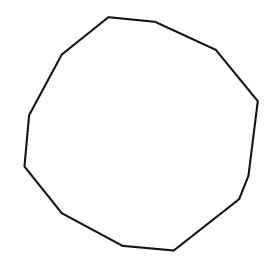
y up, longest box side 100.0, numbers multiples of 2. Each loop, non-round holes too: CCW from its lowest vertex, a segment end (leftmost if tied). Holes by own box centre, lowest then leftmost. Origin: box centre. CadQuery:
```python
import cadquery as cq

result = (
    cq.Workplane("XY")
    .moveTo(14.0, -50.0)
    .lineTo(42.0, -28.0)
    .lineTo(46.0, -18.0)
    .lineTo(50.0, 14.0)
    .lineTo(32.0, 36.0)
    .lineTo(6.0, 48.0)
    .lineTo(-14.0, 50.0)
    .lineTo(-34.0, 34.0)
    .lineTo(-48.0, 8.0)
    .lineTo(-50.0, -14.0)
    .lineTo(-34.0, -34.0)
    .lineTo(-8.0, -48.0)
    .close()
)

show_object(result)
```